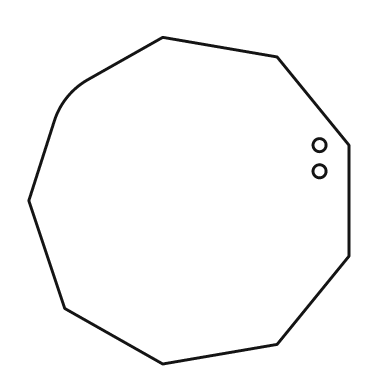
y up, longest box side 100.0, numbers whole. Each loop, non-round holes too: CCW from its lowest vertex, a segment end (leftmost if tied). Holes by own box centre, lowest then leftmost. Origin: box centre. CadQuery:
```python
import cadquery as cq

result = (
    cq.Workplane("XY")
    .moveTo(-8.0, -50.0)
    .lineTo(27.0, -44.0)
    .lineTo(49.0, -17.0)
    .lineTo(49.0, 17.0)
    .lineTo(27.0, 44.0)
    .lineTo(-8.0, 50.0)
    .lineTo(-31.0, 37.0)
    .threePointArc((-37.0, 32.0), (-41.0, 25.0))
    .lineTo(-49.0, 0.0)
    .lineTo(-38.0, -33.0)
    .close()
    .moveTo(40.0, 9.0)
    .circle(2.0)
    .moveTo(40.0, 17.0)
    .circle(2.0)
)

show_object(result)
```